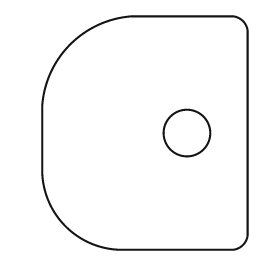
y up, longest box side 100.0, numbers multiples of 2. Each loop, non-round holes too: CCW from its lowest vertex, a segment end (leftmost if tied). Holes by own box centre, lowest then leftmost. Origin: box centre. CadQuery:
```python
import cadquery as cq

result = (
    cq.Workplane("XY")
    .moveTo(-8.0, -50.0)
    .lineTo(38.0, -50.0)
    .threePointArc((42.0, -48.0), (44.0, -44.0))
    .lineTo(44.0, 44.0)
    .threePointArc((42.0, 48.0), (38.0, 50.0))
    .lineTo(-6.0, 50.0)
    .threePointArc((-32.0, 38.0), (-44.0, 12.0))
    .lineTo(-44.0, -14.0)
    .threePointArc((-34.0, -40.0), (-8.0, -50.0))
    .close()
    .moveTo(18.0, 0.0)
    .circle(10.0)
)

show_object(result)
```